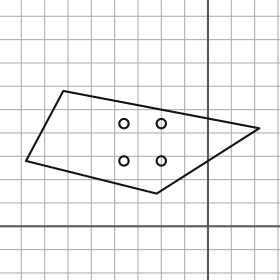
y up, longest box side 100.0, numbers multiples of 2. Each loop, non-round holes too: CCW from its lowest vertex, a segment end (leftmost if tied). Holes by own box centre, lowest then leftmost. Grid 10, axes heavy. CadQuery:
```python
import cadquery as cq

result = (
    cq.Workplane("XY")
    .moveTo(-22.0, 14.0)
    .lineTo(22.0, 42.0)
    .lineTo(-62.0, 58.0)
    .lineTo(-78.0, 28.0)
    .close()
    .moveTo(-36.0, 28.0)
    .circle(2.0)
    .moveTo(-20.0, 28.0)
    .circle(2.0)
    .moveTo(-36.0, 44.0)
    .circle(2.0)
    .moveTo(-20.0, 44.0)
    .circle(2.0)
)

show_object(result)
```